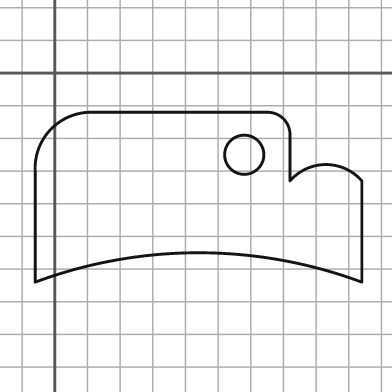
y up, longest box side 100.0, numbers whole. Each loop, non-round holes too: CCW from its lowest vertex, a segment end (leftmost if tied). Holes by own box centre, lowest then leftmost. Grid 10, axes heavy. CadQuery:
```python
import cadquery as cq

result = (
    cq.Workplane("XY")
    .moveTo(-6.0, -64.0)
    .threePointArc((44.0, -55.0), (94.0, -64.0))
    .lineTo(94.0, -33.0)
    .threePointArc((83.0, -28.0), (72.0, -33.0))
    .lineTo(72.0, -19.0)
    .threePointArc((70.0, -14.0), (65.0, -12.0))
    .lineTo(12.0, -12.0)
    .threePointArc((-1.0, -17.0), (-6.0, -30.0))
    .close()
    .moveTo(58.0, -25.0)
    .circle(6.0)
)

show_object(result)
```